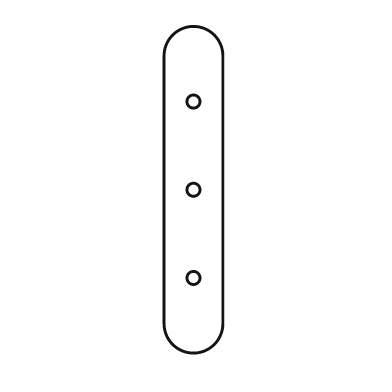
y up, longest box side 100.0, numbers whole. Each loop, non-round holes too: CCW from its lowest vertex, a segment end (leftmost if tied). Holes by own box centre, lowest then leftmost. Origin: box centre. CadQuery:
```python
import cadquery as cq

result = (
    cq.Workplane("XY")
    .moveTo(-9.0, -41.0)
    .threePointArc((0.0, -50.0), (9.0, -41.0))
    .lineTo(9.0, 41.0)
    .threePointArc((0.0, 50.0), (-9.0, 41.0))
    .close()
    .moveTo(0.0, -27.0)
    .circle(2.0)
    .moveTo(0.0, 0.0)
    .circle(2.0)
    .moveTo(0.0, 27.0)
    .circle(2.0)
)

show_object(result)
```